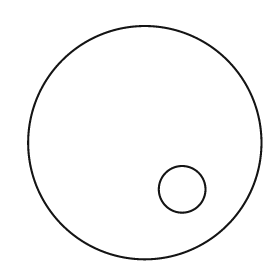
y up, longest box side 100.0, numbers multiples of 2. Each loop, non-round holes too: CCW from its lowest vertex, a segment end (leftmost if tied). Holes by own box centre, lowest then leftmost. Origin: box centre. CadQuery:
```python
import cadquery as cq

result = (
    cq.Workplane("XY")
    .moveTo(0.0, 0.0)
    .circle(50.0)
    .moveTo(16.0, -20.0)
    .circle(10.0)
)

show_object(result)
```